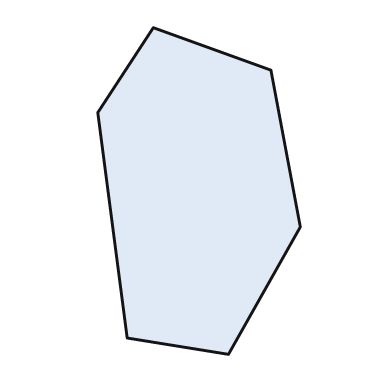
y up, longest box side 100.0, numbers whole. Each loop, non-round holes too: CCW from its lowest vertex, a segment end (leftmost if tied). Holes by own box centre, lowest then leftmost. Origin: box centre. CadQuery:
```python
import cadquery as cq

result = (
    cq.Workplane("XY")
    .moveTo(9.0, -50.0)
    .lineTo(31.0, -11.0)
    .lineTo(22.0, 37.0)
    .lineTo(-14.0, 50.0)
    .lineTo(-31.0, 24.0)
    .lineTo(-22.0, -45.0)
    .close()
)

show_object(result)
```